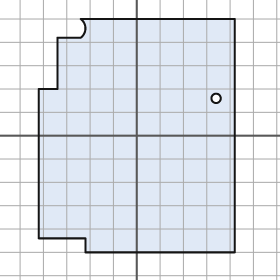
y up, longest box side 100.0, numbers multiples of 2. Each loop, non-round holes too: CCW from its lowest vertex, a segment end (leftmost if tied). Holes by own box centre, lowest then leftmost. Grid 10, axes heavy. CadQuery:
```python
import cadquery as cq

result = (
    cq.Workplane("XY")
    .moveTo(-22.0, -50.0)
    .lineTo(42.0, -50.0)
    .lineTo(42.0, 50.0)
    .lineTo(-24.0, 50.0)
    .threePointArc((-22.0, 46.0), (-24.0, 42.0))
    .lineTo(-34.0, 42.0)
    .lineTo(-34.0, 20.0)
    .lineTo(-42.0, 20.0)
    .lineTo(-42.0, -44.0)
    .lineTo(-22.0, -44.0)
    .close()
    .moveTo(34.0, 16.0)
    .circle(2.0)
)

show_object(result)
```